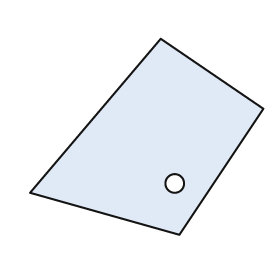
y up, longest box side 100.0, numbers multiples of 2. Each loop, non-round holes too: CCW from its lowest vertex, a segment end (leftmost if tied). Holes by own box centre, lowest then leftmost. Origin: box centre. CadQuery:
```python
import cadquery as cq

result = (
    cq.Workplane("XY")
    .moveTo(14.0, -42.0)
    .lineTo(50.0, 12.0)
    .lineTo(6.0, 42.0)
    .lineTo(-50.0, -24.0)
    .close()
    .moveTo(12.0, -20.0)
    .circle(4.0)
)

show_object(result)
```